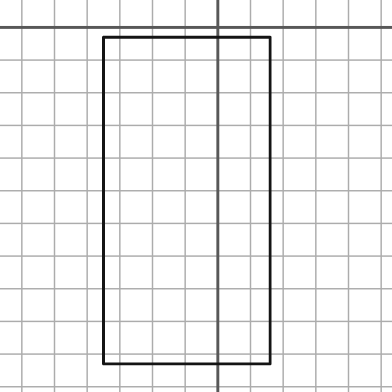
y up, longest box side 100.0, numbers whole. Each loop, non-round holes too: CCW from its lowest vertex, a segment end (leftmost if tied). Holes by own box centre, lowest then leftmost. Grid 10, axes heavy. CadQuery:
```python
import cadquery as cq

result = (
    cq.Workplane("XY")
    .moveTo(-35.0, -103.0)
    .lineTo(16.0, -103.0)
    .lineTo(16.0, -3.0)
    .lineTo(-35.0, -3.0)
    .close()
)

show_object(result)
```